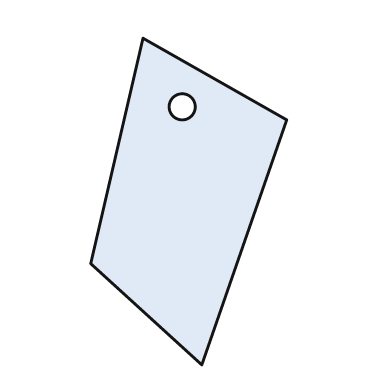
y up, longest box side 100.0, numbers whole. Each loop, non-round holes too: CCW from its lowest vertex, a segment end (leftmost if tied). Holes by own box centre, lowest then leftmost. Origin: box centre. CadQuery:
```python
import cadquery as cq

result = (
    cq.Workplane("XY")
    .moveTo(4.0, -50.0)
    .lineTo(30.0, 25.0)
    .lineTo(-14.0, 50.0)
    .lineTo(-30.0, -19.0)
    .close()
    .moveTo(-2.0, 29.0)
    .circle(4.0)
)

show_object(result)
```